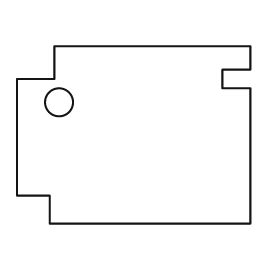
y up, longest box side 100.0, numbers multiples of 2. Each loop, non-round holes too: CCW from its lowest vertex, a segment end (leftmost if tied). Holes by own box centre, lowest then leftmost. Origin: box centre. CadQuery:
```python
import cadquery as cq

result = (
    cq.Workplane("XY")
    .moveTo(-36.0, -38.0)
    .lineTo(50.0, -38.0)
    .lineTo(50.0, 20.0)
    .lineTo(38.0, 20.0)
    .lineTo(38.0, 28.0)
    .lineTo(50.0, 28.0)
    .lineTo(50.0, 38.0)
    .lineTo(-34.0, 38.0)
    .lineTo(-34.0, 24.0)
    .lineTo(-50.0, 24.0)
    .lineTo(-50.0, -26.0)
    .lineTo(-36.0, -26.0)
    .close()
    .moveTo(-32.0, 14.0)
    .circle(6.0)
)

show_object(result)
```